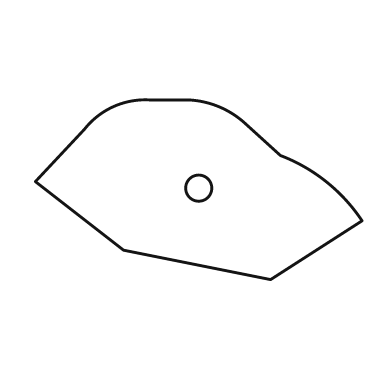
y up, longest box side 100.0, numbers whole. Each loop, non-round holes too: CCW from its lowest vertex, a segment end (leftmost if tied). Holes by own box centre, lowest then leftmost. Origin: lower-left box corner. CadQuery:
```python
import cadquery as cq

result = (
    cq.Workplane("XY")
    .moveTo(72.0, 0.0)
    .lineTo(100.0, 18.0)
    .threePointArc((89.0, 30.0), (75.0, 38.0))
    .lineTo(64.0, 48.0)
    .threePointArc((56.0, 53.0), (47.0, 55.0))
    .lineTo(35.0, 55.0)
    .threePointArc((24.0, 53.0), (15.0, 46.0))
    .lineTo(0.0, 30.0)
    .lineTo(27.0, 9.0)
    .close()
    .moveTo(50.0, 28.0)
    .circle(4.0)
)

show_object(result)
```